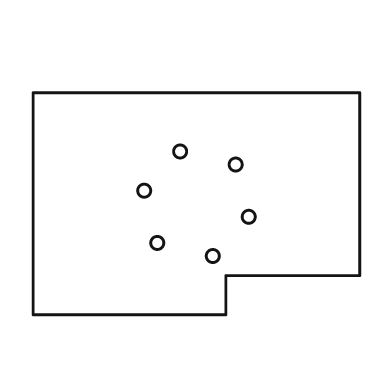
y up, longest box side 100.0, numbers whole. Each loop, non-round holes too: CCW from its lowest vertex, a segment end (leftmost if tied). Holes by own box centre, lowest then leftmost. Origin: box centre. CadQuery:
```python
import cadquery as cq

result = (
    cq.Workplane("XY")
    .moveTo(-50.0, -34.0)
    .lineTo(9.0, -34.0)
    .lineTo(9.0, -22.0)
    .lineTo(50.0, -22.0)
    .lineTo(50.0, 34.0)
    .lineTo(-50.0, 34.0)
    .close()
    .moveTo(5.0, -16.0)
    .circle(2.0)
    .moveTo(-12.0, -12.0)
    .circle(2.0)
    .moveTo(16.0, -4.0)
    .circle(2.0)
    .moveTo(-16.0, 4.0)
    .circle(2.0)
    .moveTo(12.0, 12.0)
    .circle(2.0)
    .moveTo(-5.0, 16.0)
    .circle(2.0)
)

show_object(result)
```